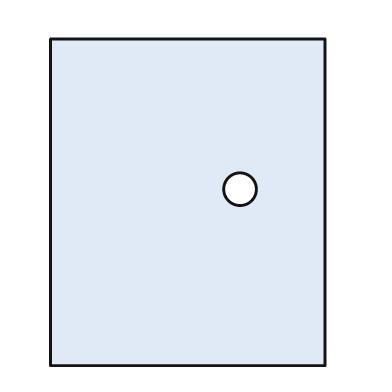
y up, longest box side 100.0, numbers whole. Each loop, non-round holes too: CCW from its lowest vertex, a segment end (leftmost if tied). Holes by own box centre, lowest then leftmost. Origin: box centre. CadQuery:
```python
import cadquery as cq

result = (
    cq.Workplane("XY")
    .moveTo(-42.0, -50.0)
    .lineTo(42.0, -50.0)
    .lineTo(42.0, 50.0)
    .lineTo(-42.0, 50.0)
    .close()
    .moveTo(16.0, 4.0)
    .circle(5.0)
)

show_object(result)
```